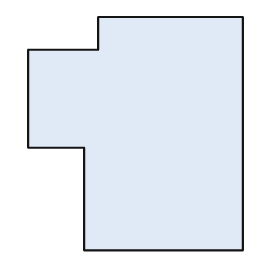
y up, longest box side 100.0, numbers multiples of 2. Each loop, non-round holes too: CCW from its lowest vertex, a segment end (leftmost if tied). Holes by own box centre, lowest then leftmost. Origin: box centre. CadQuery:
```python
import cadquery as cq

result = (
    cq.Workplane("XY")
    .moveTo(-22.0, -50.0)
    .lineTo(46.0, -50.0)
    .lineTo(46.0, 50.0)
    .lineTo(-16.0, 50.0)
    .lineTo(-16.0, 36.0)
    .lineTo(-46.0, 36.0)
    .lineTo(-46.0, -6.0)
    .lineTo(-22.0, -6.0)
    .close()
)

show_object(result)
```